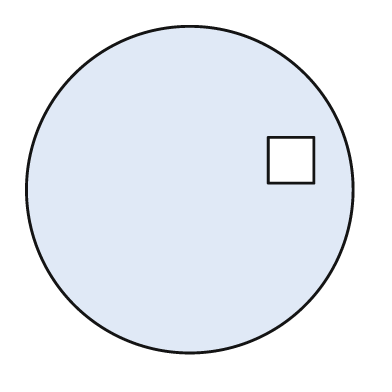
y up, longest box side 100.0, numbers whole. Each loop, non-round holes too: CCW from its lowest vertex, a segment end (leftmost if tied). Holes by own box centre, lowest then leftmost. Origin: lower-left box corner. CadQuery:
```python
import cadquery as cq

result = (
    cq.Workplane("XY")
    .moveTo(50.0, 50.0)
    .circle(50.0)
    .moveTo(74.0, 52.0)
    .lineTo(88.0, 52.0)
    .lineTo(88.0, 66.0)
    .lineTo(74.0, 66.0)
    .close()
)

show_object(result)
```